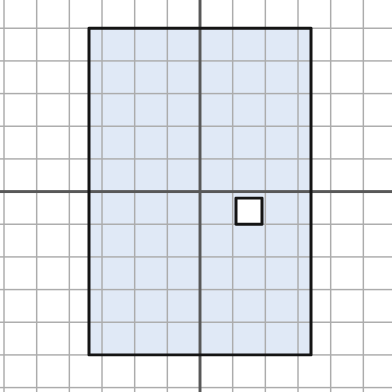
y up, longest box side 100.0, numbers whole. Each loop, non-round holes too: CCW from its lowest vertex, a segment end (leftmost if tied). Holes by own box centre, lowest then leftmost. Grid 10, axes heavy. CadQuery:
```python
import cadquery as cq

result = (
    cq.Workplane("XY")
    .moveTo(-34.0, -50.0)
    .lineTo(34.0, -50.0)
    .lineTo(34.0, 50.0)
    .lineTo(-34.0, 50.0)
    .close()
    .moveTo(11.0, -10.0)
    .lineTo(19.0, -10.0)
    .lineTo(19.0, -2.0)
    .lineTo(11.0, -2.0)
    .close()
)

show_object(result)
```